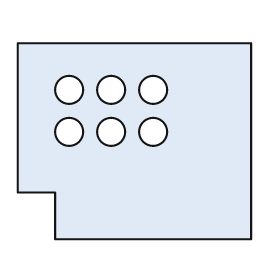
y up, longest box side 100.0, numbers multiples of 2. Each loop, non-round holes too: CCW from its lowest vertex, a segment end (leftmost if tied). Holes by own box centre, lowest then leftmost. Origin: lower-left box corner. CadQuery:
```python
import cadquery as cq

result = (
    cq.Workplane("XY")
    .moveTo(16.0, 0.0)
    .lineTo(100.0, 0.0)
    .lineTo(100.0, 84.0)
    .lineTo(0.0, 84.0)
    .lineTo(0.0, 20.0)
    .lineTo(16.0, 20.0)
    .close()
    .moveTo(22.0, 46.0)
    .circle(6.0)
    .moveTo(40.0, 46.0)
    .circle(6.0)
    .moveTo(58.0, 46.0)
    .circle(6.0)
    .moveTo(22.0, 64.0)
    .circle(6.0)
    .moveTo(40.0, 64.0)
    .circle(6.0)
    .moveTo(58.0, 64.0)
    .circle(6.0)
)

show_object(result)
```